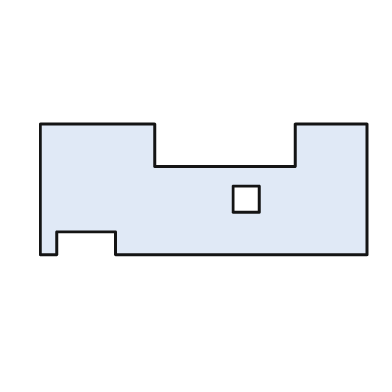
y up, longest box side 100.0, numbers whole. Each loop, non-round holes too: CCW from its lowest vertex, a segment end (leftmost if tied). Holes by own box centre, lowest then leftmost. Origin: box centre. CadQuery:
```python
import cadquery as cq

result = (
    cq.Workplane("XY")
    .moveTo(-50.0, -20.0)
    .lineTo(-45.0, -20.0)
    .lineTo(-45.0, -13.0)
    .lineTo(-27.0, -13.0)
    .lineTo(-27.0, -20.0)
    .lineTo(50.0, -20.0)
    .lineTo(50.0, 20.0)
    .lineTo(28.0, 20.0)
    .lineTo(28.0, 7.0)
    .lineTo(-15.0, 7.0)
    .lineTo(-15.0, 20.0)
    .lineTo(-50.0, 20.0)
    .close()
    .moveTo(9.0, -7.0)
    .lineTo(17.0, -7.0)
    .lineTo(17.0, 1.0)
    .lineTo(9.0, 1.0)
    .close()
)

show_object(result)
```